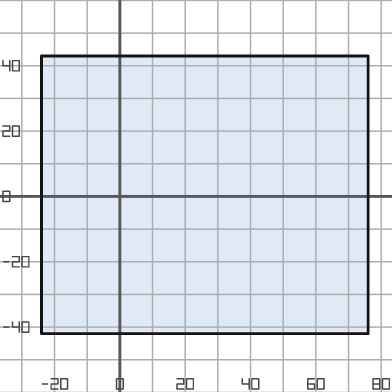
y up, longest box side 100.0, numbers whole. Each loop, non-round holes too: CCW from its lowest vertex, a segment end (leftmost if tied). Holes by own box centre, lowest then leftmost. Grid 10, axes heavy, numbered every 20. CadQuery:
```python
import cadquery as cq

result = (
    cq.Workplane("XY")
    .moveTo(-24.0, -42.0)
    .lineTo(76.0, -42.0)
    .lineTo(76.0, 43.0)
    .lineTo(-24.0, 43.0)
    .close()
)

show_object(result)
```